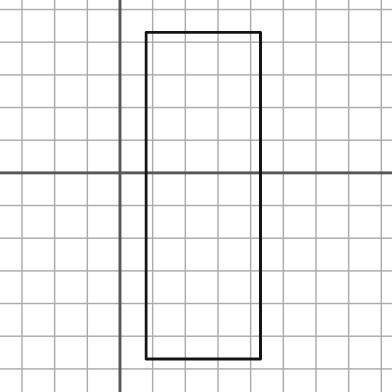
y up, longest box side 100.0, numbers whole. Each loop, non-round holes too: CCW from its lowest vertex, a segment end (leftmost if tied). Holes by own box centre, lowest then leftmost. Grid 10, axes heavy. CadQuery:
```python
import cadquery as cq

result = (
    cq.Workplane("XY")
    .moveTo(8.0, -57.0)
    .lineTo(43.0, -57.0)
    .lineTo(43.0, 43.0)
    .lineTo(8.0, 43.0)
    .close()
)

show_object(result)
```